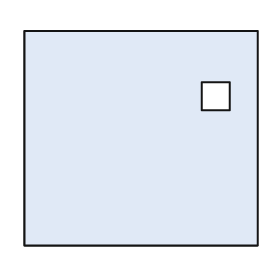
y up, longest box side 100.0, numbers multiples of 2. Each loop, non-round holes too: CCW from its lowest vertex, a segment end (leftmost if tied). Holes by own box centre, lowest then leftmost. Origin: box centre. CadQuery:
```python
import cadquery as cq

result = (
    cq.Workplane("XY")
    .moveTo(-50.0, -46.0)
    .lineTo(50.0, -46.0)
    .lineTo(50.0, 46.0)
    .lineTo(-50.0, 46.0)
    .close()
    .moveTo(26.0, 12.0)
    .lineTo(38.0, 12.0)
    .lineTo(38.0, 24.0)
    .lineTo(26.0, 24.0)
    .close()
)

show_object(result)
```